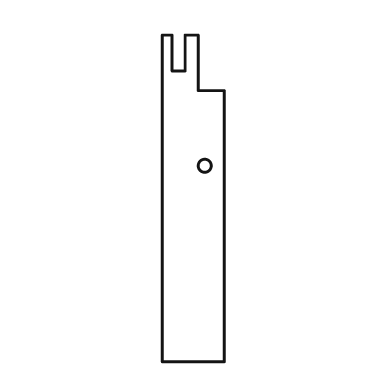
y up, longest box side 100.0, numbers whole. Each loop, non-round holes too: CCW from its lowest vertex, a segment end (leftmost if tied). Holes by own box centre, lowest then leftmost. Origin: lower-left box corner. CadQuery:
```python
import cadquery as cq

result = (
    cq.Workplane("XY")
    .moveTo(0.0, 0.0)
    .lineTo(19.0, 0.0)
    .lineTo(19.0, 83.0)
    .lineTo(11.0, 83.0)
    .lineTo(11.0, 100.0)
    .lineTo(7.0, 100.0)
    .lineTo(7.0, 89.0)
    .lineTo(3.0, 89.0)
    .lineTo(3.0, 100.0)
    .lineTo(0.0, 100.0)
    .close()
    .moveTo(13.0, 60.0)
    .circle(2.0)
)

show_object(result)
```